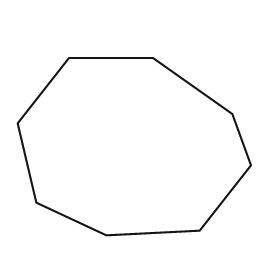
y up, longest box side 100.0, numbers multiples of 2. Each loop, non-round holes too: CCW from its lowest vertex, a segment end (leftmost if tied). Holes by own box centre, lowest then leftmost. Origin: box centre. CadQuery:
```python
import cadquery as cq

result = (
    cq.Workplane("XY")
    .moveTo(-12.0, -38.0)
    .lineTo(28.0, -36.0)
    .lineTo(50.0, -8.0)
    .lineTo(42.0, 14.0)
    .lineTo(8.0, 38.0)
    .lineTo(-28.0, 38.0)
    .lineTo(-50.0, 10.0)
    .lineTo(-42.0, -24.0)
    .close()
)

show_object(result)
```